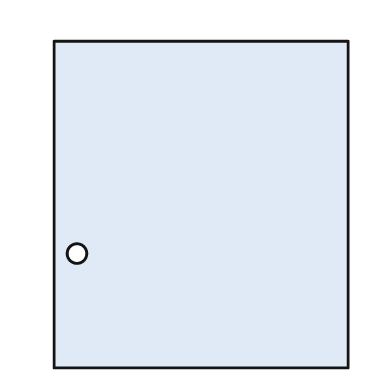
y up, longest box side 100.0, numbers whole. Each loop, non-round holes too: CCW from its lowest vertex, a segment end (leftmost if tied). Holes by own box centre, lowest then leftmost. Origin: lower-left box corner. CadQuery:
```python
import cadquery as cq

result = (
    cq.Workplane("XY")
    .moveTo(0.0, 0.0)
    .lineTo(90.0, 0.0)
    .lineTo(90.0, 100.0)
    .lineTo(0.0, 100.0)
    .close()
    .moveTo(7.0, 35.0)
    .circle(3.0)
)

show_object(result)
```